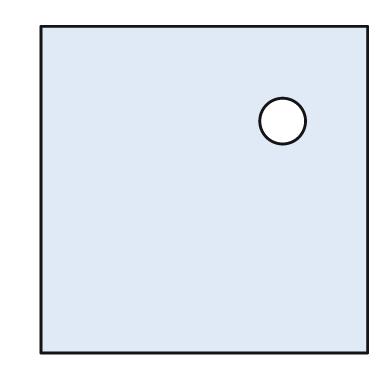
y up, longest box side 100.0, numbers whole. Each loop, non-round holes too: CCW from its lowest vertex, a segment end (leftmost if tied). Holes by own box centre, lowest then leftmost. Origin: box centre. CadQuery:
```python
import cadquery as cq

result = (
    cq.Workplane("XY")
    .moveTo(-50.0, -50.0)
    .lineTo(50.0, -50.0)
    .lineTo(50.0, 50.0)
    .lineTo(-50.0, 50.0)
    .close()
    .moveTo(24.0, 21.0)
    .circle(7.0)
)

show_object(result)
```